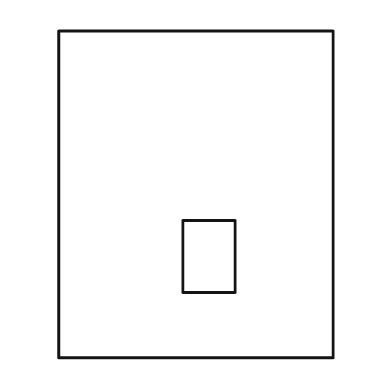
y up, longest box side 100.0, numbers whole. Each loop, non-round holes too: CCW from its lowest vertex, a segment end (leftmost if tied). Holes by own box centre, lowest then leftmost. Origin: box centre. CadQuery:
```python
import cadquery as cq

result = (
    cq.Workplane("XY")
    .moveTo(-42.0, -50.0)
    .lineTo(42.0, -50.0)
    .lineTo(42.0, 50.0)
    .lineTo(-42.0, 50.0)
    .close()
    .moveTo(-4.0, -30.0)
    .lineTo(12.0, -30.0)
    .lineTo(12.0, -8.0)
    .lineTo(-4.0, -8.0)
    .close()
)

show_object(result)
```